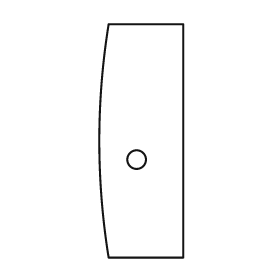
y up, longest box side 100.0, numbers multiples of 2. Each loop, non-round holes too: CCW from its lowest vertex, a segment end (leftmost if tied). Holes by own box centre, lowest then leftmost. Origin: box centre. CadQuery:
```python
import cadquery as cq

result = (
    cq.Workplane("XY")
    .moveTo(-14.0, -50.0)
    .lineTo(18.0, -50.0)
    .lineTo(18.0, 50.0)
    .lineTo(-14.0, 50.0)
    .threePointArc((-18.0, 0.0), (-14.0, -50.0))
    .close()
    .moveTo(-2.0, -8.0)
    .circle(4.0)
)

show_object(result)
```